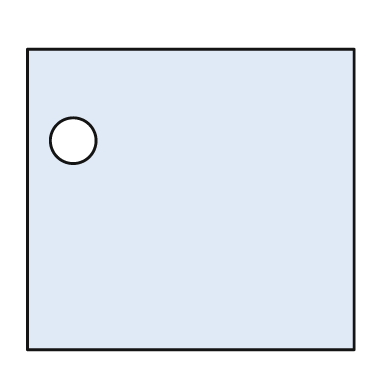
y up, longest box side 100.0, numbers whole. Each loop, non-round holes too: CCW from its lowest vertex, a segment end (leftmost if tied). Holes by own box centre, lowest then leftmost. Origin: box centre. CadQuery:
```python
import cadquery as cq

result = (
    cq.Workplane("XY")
    .moveTo(-50.0, -46.0)
    .lineTo(50.0, -46.0)
    .lineTo(50.0, 46.0)
    .lineTo(-50.0, 46.0)
    .close()
    .moveTo(-36.0, 18.0)
    .circle(7.0)
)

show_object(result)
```